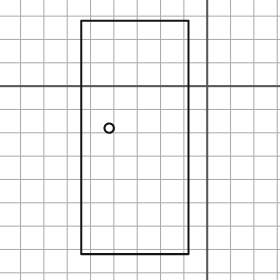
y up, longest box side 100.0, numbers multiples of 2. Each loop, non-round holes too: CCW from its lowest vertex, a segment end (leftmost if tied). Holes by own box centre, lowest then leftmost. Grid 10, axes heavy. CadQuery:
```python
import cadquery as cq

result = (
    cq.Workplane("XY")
    .moveTo(-54.0, -72.0)
    .lineTo(-8.0, -72.0)
    .lineTo(-8.0, 28.0)
    .lineTo(-54.0, 28.0)
    .close()
    .moveTo(-42.0, -18.0)
    .circle(2.0)
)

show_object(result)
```